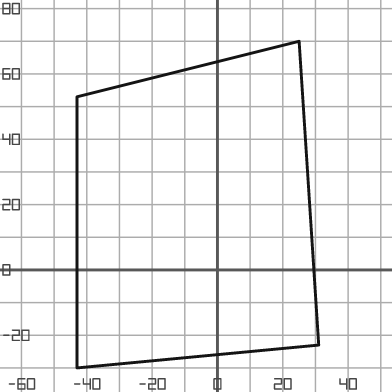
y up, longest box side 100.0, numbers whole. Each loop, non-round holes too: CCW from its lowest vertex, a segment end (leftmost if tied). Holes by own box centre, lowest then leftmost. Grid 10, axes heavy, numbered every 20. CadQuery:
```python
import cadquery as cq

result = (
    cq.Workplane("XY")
    .moveTo(-43.0, -30.0)
    .lineTo(31.0, -23.0)
    .lineTo(25.0, 70.0)
    .lineTo(-43.0, 53.0)
    .close()
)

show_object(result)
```